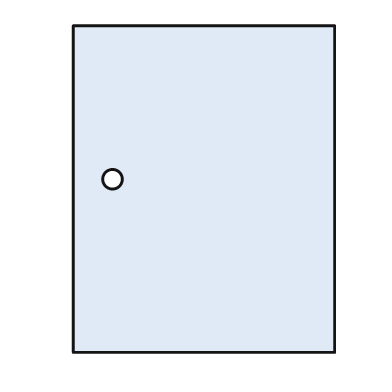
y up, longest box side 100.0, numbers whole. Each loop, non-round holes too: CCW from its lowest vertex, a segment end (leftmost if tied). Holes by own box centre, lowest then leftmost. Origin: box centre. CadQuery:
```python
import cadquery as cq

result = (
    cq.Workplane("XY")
    .moveTo(-40.0, -50.0)
    .lineTo(40.0, -50.0)
    .lineTo(40.0, 50.0)
    .lineTo(-40.0, 50.0)
    .close()
    .moveTo(-28.0, 3.0)
    .circle(3.0)
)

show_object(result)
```